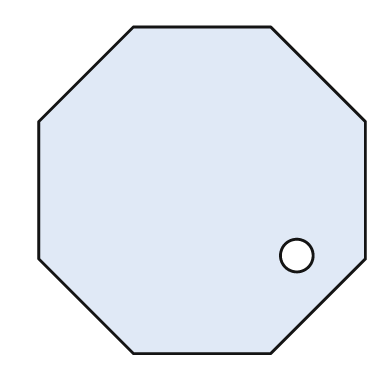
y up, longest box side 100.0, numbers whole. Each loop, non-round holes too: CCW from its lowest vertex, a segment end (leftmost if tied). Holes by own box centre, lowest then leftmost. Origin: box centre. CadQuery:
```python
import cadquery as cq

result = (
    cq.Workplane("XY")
    .moveTo(-21.0, -50.0)
    .lineTo(21.0, -50.0)
    .lineTo(50.0, -21.0)
    .lineTo(50.0, 21.0)
    .lineTo(21.0, 50.0)
    .lineTo(-21.0, 50.0)
    .lineTo(-50.0, 21.0)
    .lineTo(-50.0, -21.0)
    .close()
    .moveTo(29.0, -20.0)
    .circle(5.0)
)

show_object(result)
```